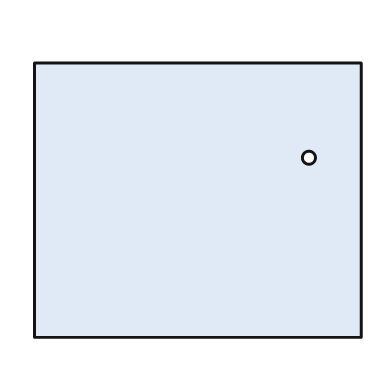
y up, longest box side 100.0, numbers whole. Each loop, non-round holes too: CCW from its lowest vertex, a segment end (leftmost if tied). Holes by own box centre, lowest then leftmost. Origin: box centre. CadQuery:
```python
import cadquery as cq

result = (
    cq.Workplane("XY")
    .moveTo(-50.0, -42.0)
    .lineTo(50.0, -42.0)
    .lineTo(50.0, 42.0)
    .lineTo(-50.0, 42.0)
    .close()
    .moveTo(34.0, 13.0)
    .circle(2.0)
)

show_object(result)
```